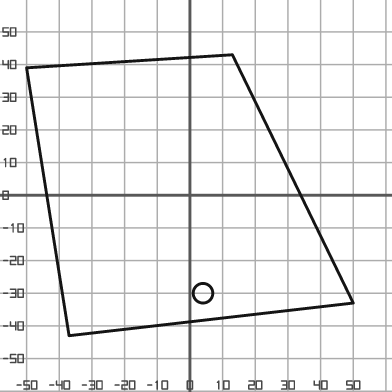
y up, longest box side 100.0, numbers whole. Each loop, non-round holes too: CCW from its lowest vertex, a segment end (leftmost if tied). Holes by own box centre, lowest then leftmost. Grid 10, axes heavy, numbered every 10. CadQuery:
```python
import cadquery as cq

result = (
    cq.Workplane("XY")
    .moveTo(-37.0, -43.0)
    .lineTo(50.0, -33.0)
    .lineTo(13.0, 43.0)
    .lineTo(-50.0, 39.0)
    .close()
    .moveTo(4.0, -30.0)
    .circle(3.0)
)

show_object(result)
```